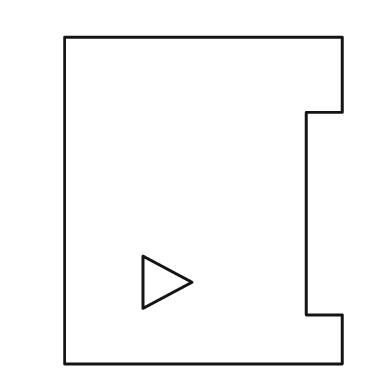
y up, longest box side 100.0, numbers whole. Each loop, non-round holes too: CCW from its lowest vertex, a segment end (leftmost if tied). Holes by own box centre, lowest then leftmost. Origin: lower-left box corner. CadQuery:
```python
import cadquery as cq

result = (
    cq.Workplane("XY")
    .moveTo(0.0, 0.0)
    .lineTo(85.0, 0.0)
    .lineTo(85.0, 15.0)
    .lineTo(74.0, 15.0)
    .lineTo(74.0, 77.0)
    .lineTo(85.0, 77.0)
    .lineTo(85.0, 100.0)
    .lineTo(0.0, 100.0)
    .close()
    .moveTo(24.0, 17.0)
    .lineTo(39.0, 25.0)
    .lineTo(24.0, 33.0)
    .close()
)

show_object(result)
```